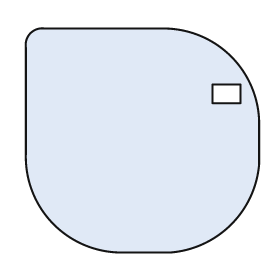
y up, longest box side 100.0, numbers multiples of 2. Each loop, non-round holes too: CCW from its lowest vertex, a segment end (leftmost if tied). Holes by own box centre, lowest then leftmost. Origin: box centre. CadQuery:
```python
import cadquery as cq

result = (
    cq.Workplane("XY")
    .moveTo(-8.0, -48.0)
    .lineTo(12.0, -48.0)
    .threePointArc((38.0, -36.0), (50.0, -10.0))
    .lineTo(50.0, 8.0)
    .threePointArc((38.0, 36.0), (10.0, 48.0))
    .lineTo(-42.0, 48.0)
    .threePointArc((-48.0, 46.0), (-50.0, 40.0))
    .lineTo(-50.0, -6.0)
    .threePointArc((-38.0, -36.0), (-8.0, -48.0))
    .close()
    .moveTo(30.0, 16.0)
    .lineTo(42.0, 16.0)
    .lineTo(42.0, 24.0)
    .lineTo(30.0, 24.0)
    .close()
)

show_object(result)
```